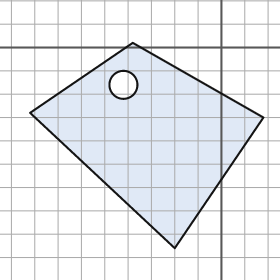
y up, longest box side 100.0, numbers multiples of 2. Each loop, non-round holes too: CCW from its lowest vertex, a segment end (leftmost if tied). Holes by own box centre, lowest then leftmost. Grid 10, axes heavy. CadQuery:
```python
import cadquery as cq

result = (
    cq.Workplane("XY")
    .moveTo(-20.0, -86.0)
    .lineTo(18.0, -30.0)
    .lineTo(-38.0, 2.0)
    .lineTo(-82.0, -28.0)
    .close()
    .moveTo(-42.0, -16.0)
    .circle(6.0)
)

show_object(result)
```